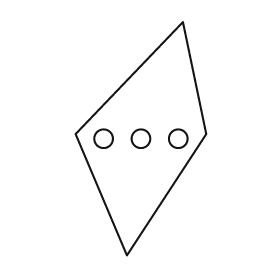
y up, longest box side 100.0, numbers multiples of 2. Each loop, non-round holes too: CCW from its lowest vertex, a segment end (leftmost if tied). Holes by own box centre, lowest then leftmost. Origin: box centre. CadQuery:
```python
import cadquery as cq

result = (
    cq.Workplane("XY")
    .moveTo(-6.0, -50.0)
    .lineTo(28.0, 2.0)
    .lineTo(18.0, 50.0)
    .lineTo(-28.0, 2.0)
    .close()
    .moveTo(-16.0, 0.0)
    .circle(4.0)
    .moveTo(0.0, 0.0)
    .circle(4.0)
    .moveTo(16.0, 0.0)
    .circle(4.0)
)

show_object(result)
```